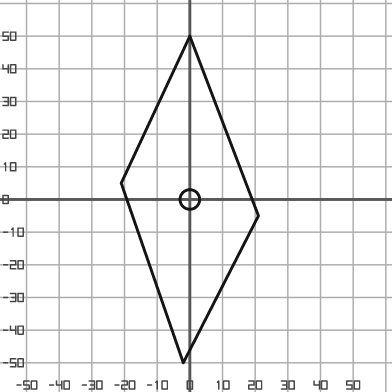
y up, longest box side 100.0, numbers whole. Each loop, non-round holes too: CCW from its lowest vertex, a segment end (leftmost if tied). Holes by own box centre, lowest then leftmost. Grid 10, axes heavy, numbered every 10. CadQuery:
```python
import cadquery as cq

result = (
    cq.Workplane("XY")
    .moveTo(-2.0, -50.0)
    .lineTo(21.0, -5.0)
    .lineTo(0.0, 50.0)
    .lineTo(-21.0, 5.0)
    .close()
    .moveTo(0.0, 0.0)
    .circle(3.0)
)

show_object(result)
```